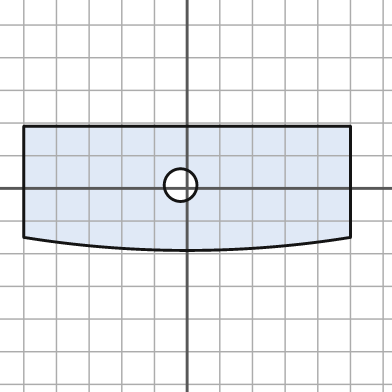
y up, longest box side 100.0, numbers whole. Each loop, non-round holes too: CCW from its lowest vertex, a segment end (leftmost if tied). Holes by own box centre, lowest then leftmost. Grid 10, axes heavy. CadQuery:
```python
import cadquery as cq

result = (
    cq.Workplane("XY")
    .moveTo(-50.0, -15.0)
    .threePointArc((0.0, -19.0), (50.0, -15.0))
    .lineTo(50.0, 19.0)
    .lineTo(-50.0, 19.0)
    .close()
    .moveTo(-2.0, 1.0)
    .circle(5.0)
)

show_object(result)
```